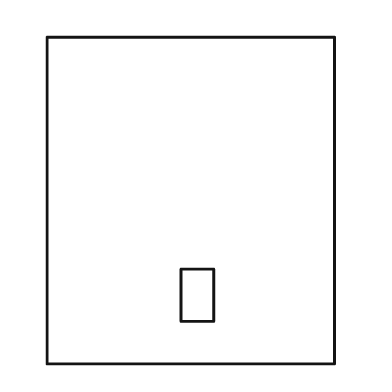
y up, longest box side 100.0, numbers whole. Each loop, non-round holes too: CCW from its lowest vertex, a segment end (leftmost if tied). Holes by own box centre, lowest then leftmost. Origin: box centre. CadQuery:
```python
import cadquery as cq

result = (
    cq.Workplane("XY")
    .moveTo(-44.0, -50.0)
    .lineTo(44.0, -50.0)
    .lineTo(44.0, 50.0)
    .lineTo(-44.0, 50.0)
    .close()
    .moveTo(-3.0, -37.0)
    .lineTo(7.0, -37.0)
    .lineTo(7.0, -21.0)
    .lineTo(-3.0, -21.0)
    .close()
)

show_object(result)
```